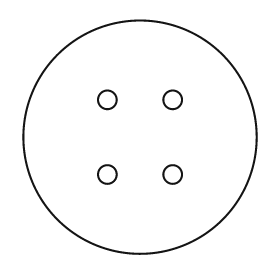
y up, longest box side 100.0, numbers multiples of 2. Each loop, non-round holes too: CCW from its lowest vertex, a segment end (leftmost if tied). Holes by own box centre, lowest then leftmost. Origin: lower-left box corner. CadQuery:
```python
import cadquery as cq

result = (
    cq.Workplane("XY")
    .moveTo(50.0, 50.0)
    .circle(50.0)
    .moveTo(36.0, 34.0)
    .circle(4.0)
    .moveTo(64.0, 34.0)
    .circle(4.0)
    .moveTo(36.0, 66.0)
    .circle(4.0)
    .moveTo(64.0, 66.0)
    .circle(4.0)
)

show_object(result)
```